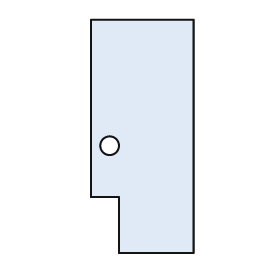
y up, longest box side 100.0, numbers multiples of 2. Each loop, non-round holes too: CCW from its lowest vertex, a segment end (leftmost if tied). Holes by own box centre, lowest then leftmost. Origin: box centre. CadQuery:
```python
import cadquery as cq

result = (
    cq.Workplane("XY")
    .moveTo(-10.0, -50.0)
    .lineTo(22.0, -50.0)
    .lineTo(22.0, 50.0)
    .lineTo(-22.0, 50.0)
    .lineTo(-22.0, -26.0)
    .lineTo(-10.0, -26.0)
    .close()
    .moveTo(-14.0, -4.0)
    .circle(4.0)
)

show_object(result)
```